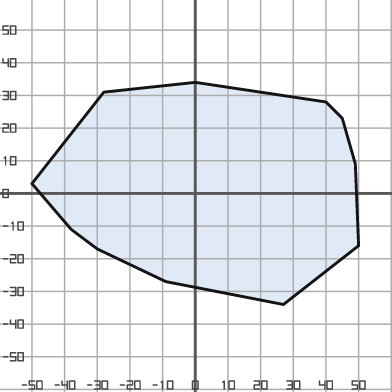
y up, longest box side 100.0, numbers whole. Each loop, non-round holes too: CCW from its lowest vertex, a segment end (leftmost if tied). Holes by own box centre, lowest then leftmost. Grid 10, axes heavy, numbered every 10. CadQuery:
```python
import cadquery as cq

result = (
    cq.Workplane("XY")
    .moveTo(27.0, -34.0)
    .lineTo(50.0, -16.0)
    .lineTo(49.0, 9.0)
    .lineTo(45.0, 23.0)
    .lineTo(40.0, 28.0)
    .lineTo(0.0, 34.0)
    .lineTo(-28.0, 31.0)
    .lineTo(-50.0, 3.0)
    .lineTo(-38.0, -11.0)
    .lineTo(-30.0, -17.0)
    .lineTo(-9.0, -27.0)
    .close()
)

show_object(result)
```